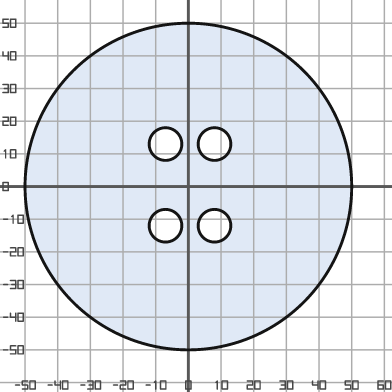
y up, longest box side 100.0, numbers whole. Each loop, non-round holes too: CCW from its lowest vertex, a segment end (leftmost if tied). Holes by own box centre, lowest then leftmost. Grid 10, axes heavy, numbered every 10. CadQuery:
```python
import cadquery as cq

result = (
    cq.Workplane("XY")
    .moveTo(0.0, 0.0)
    .circle(50.0)
    .moveTo(-7.0, -12.0)
    .circle(5.0)
    .moveTo(8.0, -12.0)
    .circle(5.0)
    .moveTo(-7.0, 13.0)
    .circle(5.0)
    .moveTo(8.0, 13.0)
    .circle(5.0)
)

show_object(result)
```